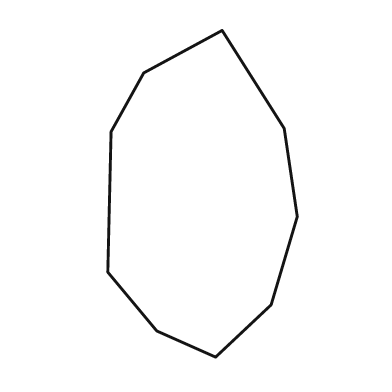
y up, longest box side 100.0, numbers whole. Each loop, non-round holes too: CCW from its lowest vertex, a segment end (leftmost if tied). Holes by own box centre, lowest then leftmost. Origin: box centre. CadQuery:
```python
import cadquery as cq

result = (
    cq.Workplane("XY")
    .moveTo(4.0, -50.0)
    .lineTo(21.0, -34.0)
    .lineTo(29.0, -7.0)
    .lineTo(25.0, 20.0)
    .lineTo(6.0, 50.0)
    .lineTo(-18.0, 37.0)
    .lineTo(-28.0, 19.0)
    .lineTo(-29.0, -24.0)
    .lineTo(-14.0, -42.0)
    .close()
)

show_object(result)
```